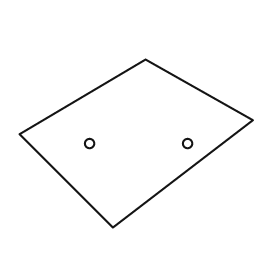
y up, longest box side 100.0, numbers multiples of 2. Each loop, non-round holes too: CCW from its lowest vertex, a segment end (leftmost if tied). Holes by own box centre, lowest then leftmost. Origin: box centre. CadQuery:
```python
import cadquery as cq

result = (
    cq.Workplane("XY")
    .moveTo(-10.0, -36.0)
    .lineTo(50.0, 10.0)
    .lineTo(4.0, 36.0)
    .lineTo(-50.0, 4.0)
    .close()
    .moveTo(-20.0, 0.0)
    .circle(2.0)
    .moveTo(22.0, 0.0)
    .circle(2.0)
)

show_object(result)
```